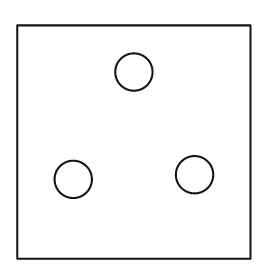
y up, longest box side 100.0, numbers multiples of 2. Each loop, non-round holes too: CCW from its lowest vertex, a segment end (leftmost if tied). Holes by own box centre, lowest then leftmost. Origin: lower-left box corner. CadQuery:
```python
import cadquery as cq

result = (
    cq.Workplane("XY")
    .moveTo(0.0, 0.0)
    .lineTo(100.0, 0.0)
    .lineTo(100.0, 100.0)
    .lineTo(0.0, 100.0)
    .close()
    .moveTo(24.0, 34.0)
    .circle(8.0)
    .moveTo(76.0, 36.0)
    .circle(8.0)
    .moveTo(50.0, 80.0)
    .circle(8.0)
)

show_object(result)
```